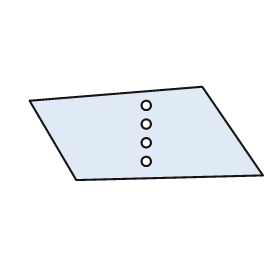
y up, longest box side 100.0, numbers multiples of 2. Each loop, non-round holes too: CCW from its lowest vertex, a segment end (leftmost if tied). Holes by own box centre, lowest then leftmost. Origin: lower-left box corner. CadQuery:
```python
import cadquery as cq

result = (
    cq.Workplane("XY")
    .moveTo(20.0, 0.0)
    .lineTo(100.0, 2.0)
    .lineTo(74.0, 40.0)
    .lineTo(0.0, 34.0)
    .close()
    .moveTo(50.0, 8.0)
    .circle(2.0)
    .moveTo(50.0, 16.0)
    .circle(2.0)
    .moveTo(50.0, 24.0)
    .circle(2.0)
    .moveTo(50.0, 32.0)
    .circle(2.0)
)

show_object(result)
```